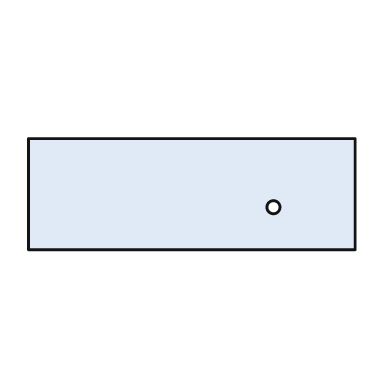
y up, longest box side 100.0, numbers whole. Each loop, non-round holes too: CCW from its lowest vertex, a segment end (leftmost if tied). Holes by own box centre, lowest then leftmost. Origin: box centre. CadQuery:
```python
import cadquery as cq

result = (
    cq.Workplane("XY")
    .moveTo(-50.0, -17.0)
    .lineTo(50.0, -17.0)
    .lineTo(50.0, 17.0)
    .lineTo(-50.0, 17.0)
    .close()
    .moveTo(25.0, -4.0)
    .circle(2.0)
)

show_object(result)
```